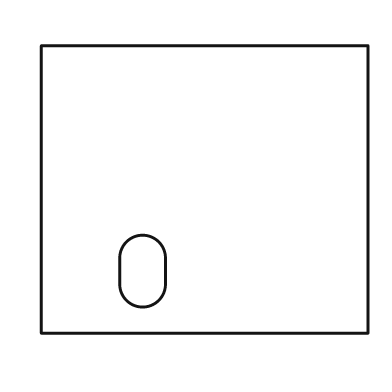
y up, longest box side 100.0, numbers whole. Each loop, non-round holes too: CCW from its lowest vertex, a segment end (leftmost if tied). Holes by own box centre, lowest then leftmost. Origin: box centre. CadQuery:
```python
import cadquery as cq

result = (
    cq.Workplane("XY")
    .moveTo(-50.0, -44.0)
    .lineTo(50.0, -44.0)
    .lineTo(50.0, 44.0)
    .lineTo(-50.0, 44.0)
    .close()
    .moveTo(-26.0, -29.0)
    .threePointArc((-19.0, -36.0), (-12.0, -29.0))
    .lineTo(-12.0, -21.0)
    .threePointArc((-19.0, -14.0), (-26.0, -21.0))
    .close()
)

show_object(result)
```